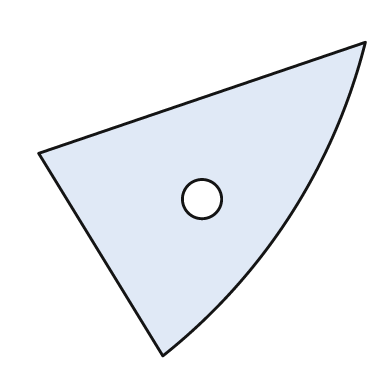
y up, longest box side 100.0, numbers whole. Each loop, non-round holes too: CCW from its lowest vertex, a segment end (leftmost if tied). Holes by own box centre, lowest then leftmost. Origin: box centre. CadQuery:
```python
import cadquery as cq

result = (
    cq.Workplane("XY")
    .moveTo(-12.0, -48.0)
    .threePointArc((27.0, -5.0), (50.0, 48.0))
    .lineTo(-50.0, 14.0)
    .close()
    .moveTo(0.0, 0.0)
    .circle(6.0)
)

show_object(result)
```